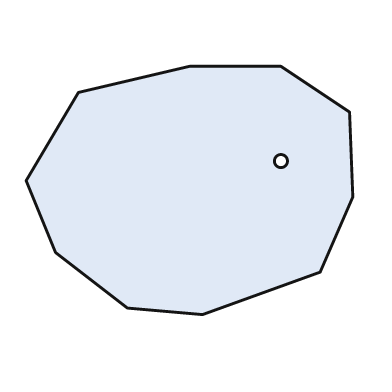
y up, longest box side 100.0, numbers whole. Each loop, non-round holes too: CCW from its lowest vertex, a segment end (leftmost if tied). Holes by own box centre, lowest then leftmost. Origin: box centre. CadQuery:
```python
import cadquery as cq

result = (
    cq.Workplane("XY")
    .moveTo(4.0, -38.0)
    .lineTo(40.0, -25.0)
    .lineTo(50.0, -2.0)
    .lineTo(49.0, 24.0)
    .lineTo(28.0, 38.0)
    .lineTo(0.0, 38.0)
    .lineTo(-34.0, 30.0)
    .lineTo(-50.0, 3.0)
    .lineTo(-41.0, -19.0)
    .lineTo(-19.0, -36.0)
    .close()
    .moveTo(28.0, 9.0)
    .circle(2.0)
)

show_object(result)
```